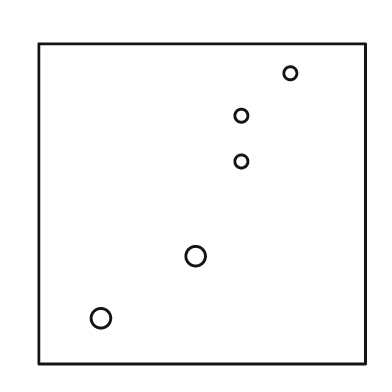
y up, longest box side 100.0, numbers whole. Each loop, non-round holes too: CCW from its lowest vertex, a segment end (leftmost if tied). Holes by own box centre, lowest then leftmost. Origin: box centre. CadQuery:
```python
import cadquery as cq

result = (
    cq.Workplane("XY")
    .moveTo(-50.0, -49.0)
    .lineTo(50.0, -49.0)
    .lineTo(50.0, 49.0)
    .lineTo(-50.0, 49.0)
    .close()
    .moveTo(-31.0, -35.0)
    .circle(3.0)
    .moveTo(-2.0, -16.0)
    .circle(3.0)
    .moveTo(12.0, 13.0)
    .circle(2.0)
    .moveTo(12.0, 27.0)
    .circle(2.0)
    .moveTo(27.0, 40.0)
    .circle(2.0)
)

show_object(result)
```